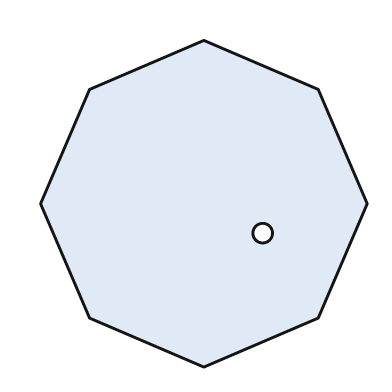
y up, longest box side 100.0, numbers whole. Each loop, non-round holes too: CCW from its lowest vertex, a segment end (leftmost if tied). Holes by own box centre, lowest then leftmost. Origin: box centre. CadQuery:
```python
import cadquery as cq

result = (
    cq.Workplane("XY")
    .moveTo(0.0, -50.0)
    .lineTo(35.0, -35.0)
    .lineTo(50.0, 0.0)
    .lineTo(35.0, 35.0)
    .lineTo(0.0, 50.0)
    .lineTo(-35.0, 35.0)
    .lineTo(-50.0, 0.0)
    .lineTo(-35.0, -35.0)
    .close()
    .moveTo(18.0, -9.0)
    .circle(3.0)
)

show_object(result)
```